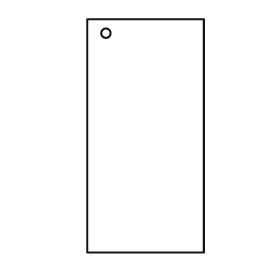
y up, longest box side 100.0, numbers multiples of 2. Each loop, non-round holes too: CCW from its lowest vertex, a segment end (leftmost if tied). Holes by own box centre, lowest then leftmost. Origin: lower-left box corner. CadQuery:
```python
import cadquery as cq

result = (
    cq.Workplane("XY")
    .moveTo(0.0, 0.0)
    .lineTo(50.0, 0.0)
    .lineTo(50.0, 100.0)
    .lineTo(0.0, 100.0)
    .close()
    .moveTo(8.0, 94.0)
    .circle(2.0)
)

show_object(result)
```